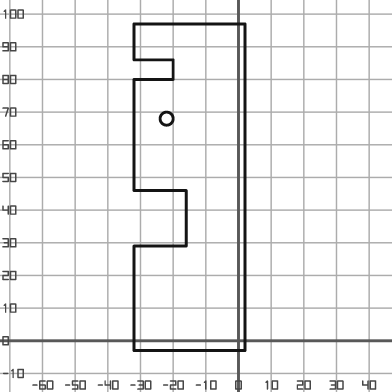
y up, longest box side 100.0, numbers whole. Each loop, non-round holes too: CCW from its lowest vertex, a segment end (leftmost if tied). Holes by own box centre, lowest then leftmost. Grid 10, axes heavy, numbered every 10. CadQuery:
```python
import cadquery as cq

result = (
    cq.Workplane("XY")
    .moveTo(-32.0, -3.0)
    .lineTo(2.0, -3.0)
    .lineTo(2.0, 97.0)
    .lineTo(-32.0, 97.0)
    .lineTo(-32.0, 86.0)
    .lineTo(-20.0, 86.0)
    .lineTo(-20.0, 80.0)
    .lineTo(-32.0, 80.0)
    .lineTo(-32.0, 46.0)
    .lineTo(-16.0, 46.0)
    .lineTo(-16.0, 29.0)
    .lineTo(-32.0, 29.0)
    .close()
    .moveTo(-22.0, 68.0)
    .circle(2.0)
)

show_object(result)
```